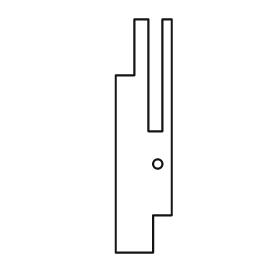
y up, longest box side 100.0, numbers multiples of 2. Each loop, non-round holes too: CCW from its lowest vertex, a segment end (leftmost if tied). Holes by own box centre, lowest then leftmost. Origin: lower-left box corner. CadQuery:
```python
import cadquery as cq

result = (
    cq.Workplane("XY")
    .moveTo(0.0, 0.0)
    .lineTo(16.0, 0.0)
    .lineTo(16.0, 16.0)
    .lineTo(24.0, 16.0)
    .lineTo(24.0, 100.0)
    .lineTo(20.0, 100.0)
    .lineTo(20.0, 52.0)
    .lineTo(14.0, 52.0)
    .lineTo(14.0, 100.0)
    .lineTo(8.0, 100.0)
    .lineTo(8.0, 76.0)
    .lineTo(0.0, 76.0)
    .close()
    .moveTo(18.0, 38.0)
    .circle(2.0)
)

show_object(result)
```